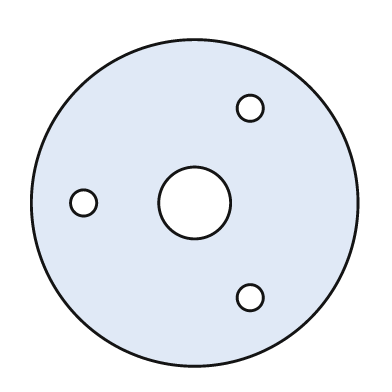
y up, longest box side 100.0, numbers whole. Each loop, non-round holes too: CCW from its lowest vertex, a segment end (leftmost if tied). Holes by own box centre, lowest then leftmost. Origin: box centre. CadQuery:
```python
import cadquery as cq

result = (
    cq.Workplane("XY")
    .moveTo(0.0, 0.0)
    .circle(50.0)
    .moveTo(17.0, -29.0)
    .circle(4.0)
    .moveTo(-34.0, 0.0)
    .circle(4.0)
    .moveTo(0.0, 0.0)
    .circle(11.0)
    .moveTo(17.0, 29.0)
    .circle(4.0)
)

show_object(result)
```